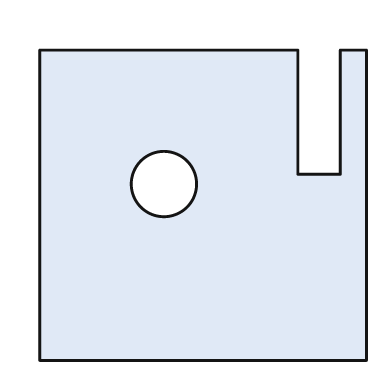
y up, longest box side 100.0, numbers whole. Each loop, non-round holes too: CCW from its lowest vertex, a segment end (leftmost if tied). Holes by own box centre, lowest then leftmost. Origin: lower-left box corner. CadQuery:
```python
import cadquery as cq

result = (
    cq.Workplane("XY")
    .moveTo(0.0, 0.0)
    .lineTo(100.0, 0.0)
    .lineTo(100.0, 95.0)
    .lineTo(92.0, 95.0)
    .lineTo(92.0, 57.0)
    .lineTo(79.0, 57.0)
    .lineTo(79.0, 95.0)
    .lineTo(0.0, 95.0)
    .close()
    .moveTo(38.0, 54.0)
    .circle(10.0)
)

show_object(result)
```